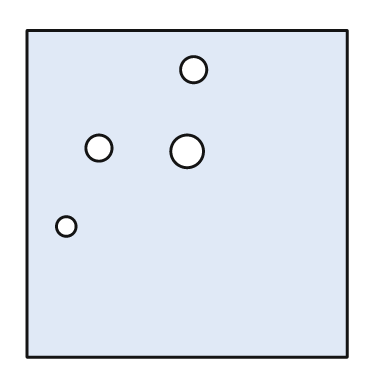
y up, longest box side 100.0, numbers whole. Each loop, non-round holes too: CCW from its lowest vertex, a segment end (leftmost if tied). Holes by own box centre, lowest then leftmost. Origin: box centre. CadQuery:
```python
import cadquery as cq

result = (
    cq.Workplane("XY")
    .moveTo(-49.0, -50.0)
    .lineTo(49.0, -50.0)
    .lineTo(49.0, 50.0)
    .lineTo(-49.0, 50.0)
    .close()
    .moveTo(-37.0, -10.0)
    .circle(3.0)
    .moveTo(0.0, 13.0)
    .circle(5.0)
    .moveTo(-27.0, 14.0)
    .circle(4.0)
    .moveTo(2.0, 38.0)
    .circle(4.0)
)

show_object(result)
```